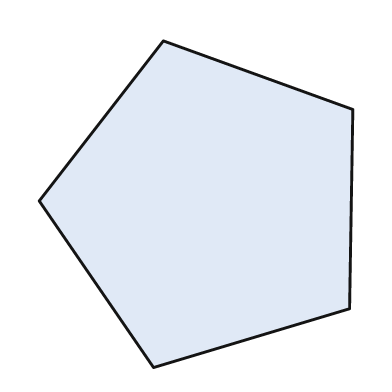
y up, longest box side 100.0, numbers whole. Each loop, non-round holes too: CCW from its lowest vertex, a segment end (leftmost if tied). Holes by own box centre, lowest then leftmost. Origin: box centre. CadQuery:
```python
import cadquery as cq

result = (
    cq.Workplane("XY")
    .moveTo(-13.0, -50.0)
    .lineTo(47.0, -32.0)
    .lineTo(48.0, 29.0)
    .lineTo(-10.0, 50.0)
    .lineTo(-48.0, 1.0)
    .close()
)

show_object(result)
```